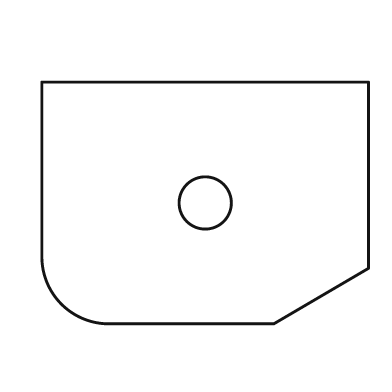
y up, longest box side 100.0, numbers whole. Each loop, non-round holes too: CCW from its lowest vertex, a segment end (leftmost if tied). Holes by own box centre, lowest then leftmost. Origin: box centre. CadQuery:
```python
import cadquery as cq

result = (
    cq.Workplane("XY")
    .moveTo(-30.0, -37.0)
    .lineTo(21.0, -37.0)
    .lineTo(50.0, -20.0)
    .lineTo(50.0, 37.0)
    .lineTo(-50.0, 37.0)
    .lineTo(-50.0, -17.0)
    .threePointArc((-44.0, -31.0), (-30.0, -37.0))
    .close()
    .moveTo(0.0, 0.0)
    .circle(8.0)
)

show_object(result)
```